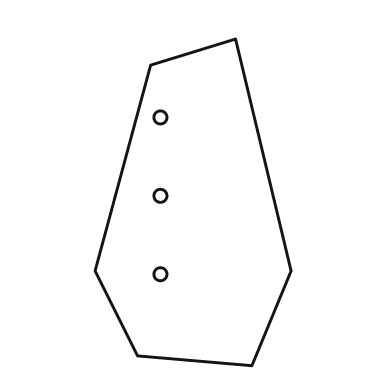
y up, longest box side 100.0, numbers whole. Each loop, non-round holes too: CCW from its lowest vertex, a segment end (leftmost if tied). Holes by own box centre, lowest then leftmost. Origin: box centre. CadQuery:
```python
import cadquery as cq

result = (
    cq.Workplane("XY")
    .moveTo(18.0, -50.0)
    .lineTo(30.0, -21.0)
    .lineTo(13.0, 50.0)
    .lineTo(-13.0, 42.0)
    .lineTo(-30.0, -21.0)
    .lineTo(-17.0, -47.0)
    .close()
    .moveTo(-10.0, -22.0)
    .circle(2.0)
    .moveTo(-10.0, 2.0)
    .circle(2.0)
    .moveTo(-10.0, 26.0)
    .circle(2.0)
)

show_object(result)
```